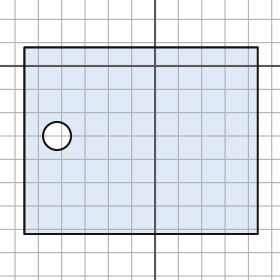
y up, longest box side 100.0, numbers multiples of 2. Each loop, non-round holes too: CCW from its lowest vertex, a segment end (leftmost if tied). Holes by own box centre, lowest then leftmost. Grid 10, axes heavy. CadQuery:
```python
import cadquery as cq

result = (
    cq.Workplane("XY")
    .moveTo(-56.0, -72.0)
    .lineTo(44.0, -72.0)
    .lineTo(44.0, 8.0)
    .lineTo(-56.0, 8.0)
    .close()
    .moveTo(-42.0, -30.0)
    .circle(6.0)
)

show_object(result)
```